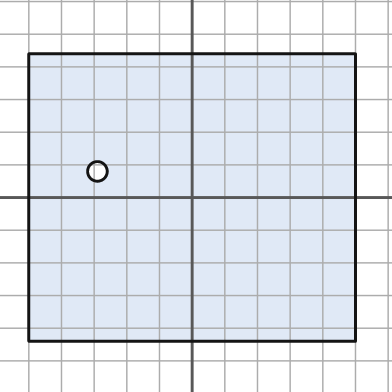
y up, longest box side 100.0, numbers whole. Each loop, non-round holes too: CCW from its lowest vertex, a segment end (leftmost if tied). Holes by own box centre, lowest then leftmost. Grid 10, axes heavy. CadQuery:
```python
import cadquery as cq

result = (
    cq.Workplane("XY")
    .moveTo(-50.0, -44.0)
    .lineTo(50.0, -44.0)
    .lineTo(50.0, 44.0)
    .lineTo(-50.0, 44.0)
    .close()
    .moveTo(-29.0, 8.0)
    .circle(3.0)
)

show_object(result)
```